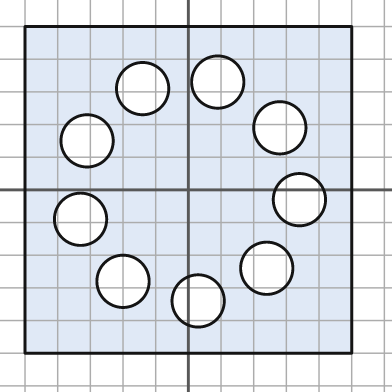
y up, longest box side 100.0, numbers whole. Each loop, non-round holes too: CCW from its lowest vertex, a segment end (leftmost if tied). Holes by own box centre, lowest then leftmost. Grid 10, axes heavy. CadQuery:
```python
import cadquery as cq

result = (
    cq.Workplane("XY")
    .moveTo(-50.0, -50.0)
    .lineTo(50.0, -50.0)
    .lineTo(50.0, 50.0)
    .lineTo(-50.0, 50.0)
    .close()
    .moveTo(3.0, -34.0)
    .circle(8.0)
    .moveTo(-20.0, -28.0)
    .circle(8.0)
    .moveTo(24.0, -24.0)
    .circle(8.0)
    .moveTo(-33.0, -9.0)
    .circle(8.0)
    .moveTo(34.0, -3.0)
    .circle(8.0)
    .moveTo(-31.0, 15.0)
    .circle(8.0)
    .moveTo(28.0, 19.0)
    .circle(8.0)
    .moveTo(-14.0, 31.0)
    .circle(8.0)
    .moveTo(9.0, 33.0)
    .circle(8.0)
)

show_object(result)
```